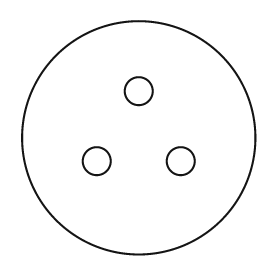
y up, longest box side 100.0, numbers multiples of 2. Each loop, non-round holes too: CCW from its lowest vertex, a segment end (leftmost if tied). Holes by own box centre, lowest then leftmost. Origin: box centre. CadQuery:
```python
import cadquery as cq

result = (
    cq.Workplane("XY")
    .moveTo(0.0, 0.0)
    .circle(50.0)
    .moveTo(-18.0, -10.0)
    .circle(6.0)
    .moveTo(18.0, -10.0)
    .circle(6.0)
    .moveTo(0.0, 20.0)
    .circle(6.0)
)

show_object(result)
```